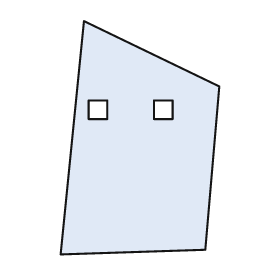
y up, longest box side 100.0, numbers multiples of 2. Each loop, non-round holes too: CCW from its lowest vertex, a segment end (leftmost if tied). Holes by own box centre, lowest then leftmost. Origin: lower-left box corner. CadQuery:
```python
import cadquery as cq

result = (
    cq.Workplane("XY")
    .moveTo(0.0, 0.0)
    .lineTo(62.0, 2.0)
    .lineTo(68.0, 72.0)
    .lineTo(10.0, 100.0)
    .close()
    .moveTo(12.0, 58.0)
    .lineTo(20.0, 58.0)
    .lineTo(20.0, 66.0)
    .lineTo(12.0, 66.0)
    .close()
    .moveTo(40.0, 58.0)
    .lineTo(48.0, 58.0)
    .lineTo(48.0, 66.0)
    .lineTo(40.0, 66.0)
    .close()
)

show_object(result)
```